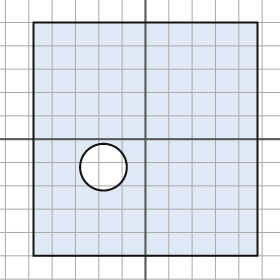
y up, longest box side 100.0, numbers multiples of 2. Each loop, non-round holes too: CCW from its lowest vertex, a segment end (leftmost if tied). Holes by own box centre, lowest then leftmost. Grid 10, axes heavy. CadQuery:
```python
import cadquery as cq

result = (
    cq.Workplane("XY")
    .moveTo(-48.0, -50.0)
    .lineTo(48.0, -50.0)
    .lineTo(48.0, 50.0)
    .lineTo(-48.0, 50.0)
    .close()
    .moveTo(-18.0, -12.0)
    .circle(10.0)
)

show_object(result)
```